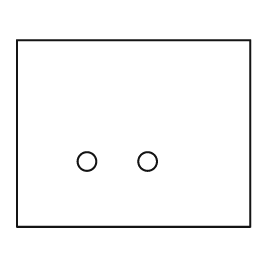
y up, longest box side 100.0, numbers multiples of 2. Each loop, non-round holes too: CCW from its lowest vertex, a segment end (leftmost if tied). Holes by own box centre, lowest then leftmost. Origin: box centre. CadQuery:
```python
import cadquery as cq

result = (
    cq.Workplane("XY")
    .moveTo(-50.0, -40.0)
    .lineTo(50.0, -40.0)
    .lineTo(50.0, 40.0)
    .lineTo(-50.0, 40.0)
    .close()
    .moveTo(-20.0, -12.0)
    .circle(4.0)
    .moveTo(6.0, -12.0)
    .circle(4.0)
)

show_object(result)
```